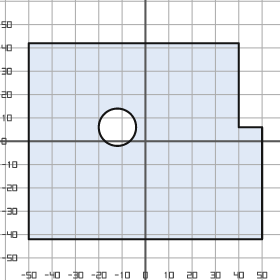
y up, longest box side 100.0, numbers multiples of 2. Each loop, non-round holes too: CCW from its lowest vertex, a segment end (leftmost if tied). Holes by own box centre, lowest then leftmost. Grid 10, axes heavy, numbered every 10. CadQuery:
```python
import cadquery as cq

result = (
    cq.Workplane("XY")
    .moveTo(-50.0, -42.0)
    .lineTo(50.0, -42.0)
    .lineTo(50.0, 6.0)
    .lineTo(40.0, 6.0)
    .lineTo(40.0, 42.0)
    .lineTo(-50.0, 42.0)
    .close()
    .moveTo(-12.0, 6.0)
    .circle(8.0)
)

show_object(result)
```